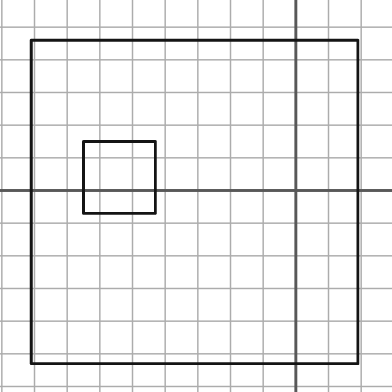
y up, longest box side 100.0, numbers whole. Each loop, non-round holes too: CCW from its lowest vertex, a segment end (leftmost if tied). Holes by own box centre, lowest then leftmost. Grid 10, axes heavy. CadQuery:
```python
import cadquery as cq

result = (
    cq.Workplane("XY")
    .moveTo(-81.0, -53.0)
    .lineTo(19.0, -53.0)
    .lineTo(19.0, 46.0)
    .lineTo(-81.0, 46.0)
    .close()
    .moveTo(-65.0, -7.0)
    .lineTo(-43.0, -7.0)
    .lineTo(-43.0, 15.0)
    .lineTo(-65.0, 15.0)
    .close()
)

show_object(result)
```